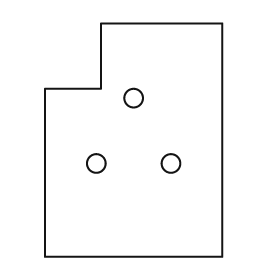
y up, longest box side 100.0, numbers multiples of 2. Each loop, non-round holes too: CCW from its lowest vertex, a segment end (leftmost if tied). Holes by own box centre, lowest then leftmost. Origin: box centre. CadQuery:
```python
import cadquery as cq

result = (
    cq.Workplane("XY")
    .moveTo(-38.0, -50.0)
    .lineTo(38.0, -50.0)
    .lineTo(38.0, 50.0)
    .lineTo(-14.0, 50.0)
    .lineTo(-14.0, 22.0)
    .lineTo(-38.0, 22.0)
    .close()
    .moveTo(-16.0, -10.0)
    .circle(4.0)
    .moveTo(16.0, -10.0)
    .circle(4.0)
    .moveTo(0.0, 18.0)
    .circle(4.0)
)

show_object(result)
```